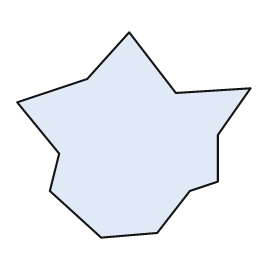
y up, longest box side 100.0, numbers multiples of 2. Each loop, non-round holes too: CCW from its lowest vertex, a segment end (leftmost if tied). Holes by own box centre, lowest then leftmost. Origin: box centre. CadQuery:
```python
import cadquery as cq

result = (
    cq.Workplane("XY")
    .moveTo(-14.0, -44.0)
    .lineTo(10.0, -42.0)
    .lineTo(24.0, -24.0)
    .lineTo(36.0, -20.0)
    .lineTo(36.0, 0.0)
    .lineTo(50.0, 20.0)
    .lineTo(18.0, 18.0)
    .lineTo(-2.0, 44.0)
    .lineTo(-20.0, 24.0)
    .lineTo(-50.0, 14.0)
    .lineTo(-32.0, -8.0)
    .lineTo(-36.0, -24.0)
    .close()
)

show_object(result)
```